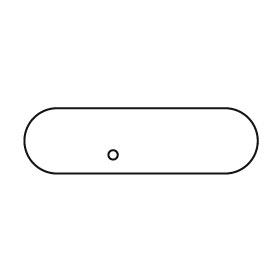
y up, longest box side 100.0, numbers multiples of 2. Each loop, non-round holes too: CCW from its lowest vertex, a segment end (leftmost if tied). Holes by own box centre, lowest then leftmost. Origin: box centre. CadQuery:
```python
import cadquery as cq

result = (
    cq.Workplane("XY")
    .moveTo(-36.0, -14.0)
    .lineTo(36.0, -14.0)
    .threePointArc((50.0, 0.0), (36.0, 14.0))
    .lineTo(-36.0, 14.0)
    .threePointArc((-50.0, 0.0), (-36.0, -14.0))
    .close()
    .moveTo(-12.0, -6.0)
    .circle(2.0)
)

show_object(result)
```